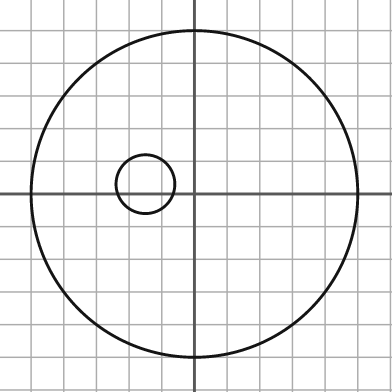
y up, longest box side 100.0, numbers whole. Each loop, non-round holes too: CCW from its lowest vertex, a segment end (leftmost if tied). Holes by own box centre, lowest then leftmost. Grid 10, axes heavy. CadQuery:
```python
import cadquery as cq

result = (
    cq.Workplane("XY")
    .moveTo(0.0, 0.0)
    .circle(50.0)
    .moveTo(-15.0, 3.0)
    .circle(9.0)
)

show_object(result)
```